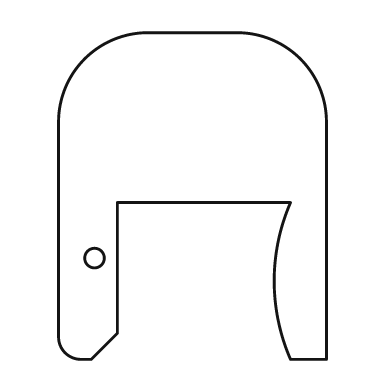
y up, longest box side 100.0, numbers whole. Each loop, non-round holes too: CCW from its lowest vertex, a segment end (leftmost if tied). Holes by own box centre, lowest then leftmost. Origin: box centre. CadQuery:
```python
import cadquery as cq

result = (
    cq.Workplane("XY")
    .moveTo(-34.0, -50.0)
    .lineTo(-31.0, -50.0)
    .lineTo(-23.0, -42.0)
    .lineTo(-23.0, -2.0)
    .lineTo(30.0, -2.0)
    .threePointArc((25.0, -26.0), (30.0, -50.0))
    .lineTo(41.0, -50.0)
    .lineTo(41.0, 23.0)
    .threePointArc((33.0, 42.0), (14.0, 50.0))
    .lineTo(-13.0, 50.0)
    .threePointArc((-33.0, 42.0), (-41.0, 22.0))
    .lineTo(-41.0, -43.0)
    .threePointArc((-39.0, -48.0), (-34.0, -50.0))
    .close()
    .moveTo(-30.0, -19.0)
    .circle(3.0)
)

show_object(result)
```